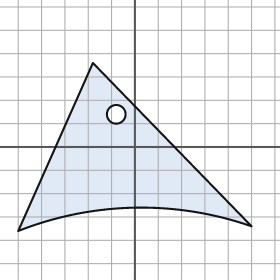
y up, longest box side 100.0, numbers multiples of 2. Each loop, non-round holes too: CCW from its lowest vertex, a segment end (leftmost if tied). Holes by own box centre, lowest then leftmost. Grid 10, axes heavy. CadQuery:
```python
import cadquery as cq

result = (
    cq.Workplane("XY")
    .moveTo(-50.0, -36.0)
    .threePointArc((0.0, -26.0), (50.0, -34.0))
    .lineTo(-18.0, 36.0)
    .close()
    .moveTo(-8.0, 14.0)
    .circle(4.0)
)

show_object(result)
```